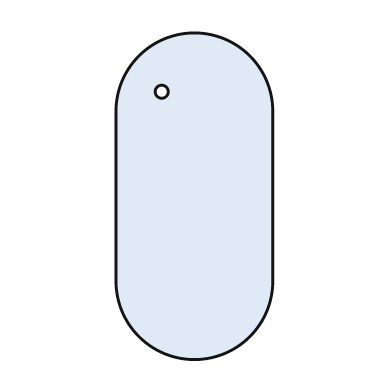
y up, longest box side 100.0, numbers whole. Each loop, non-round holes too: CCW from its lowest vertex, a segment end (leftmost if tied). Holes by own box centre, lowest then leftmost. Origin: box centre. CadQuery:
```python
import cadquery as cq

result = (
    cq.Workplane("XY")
    .moveTo(-24.0, -26.0)
    .threePointArc((0.0, -50.0), (24.0, -26.0))
    .lineTo(24.0, 26.0)
    .threePointArc((0.0, 50.0), (-24.0, 26.0))
    .close()
    .moveTo(-10.0, 32.0)
    .circle(2.0)
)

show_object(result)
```